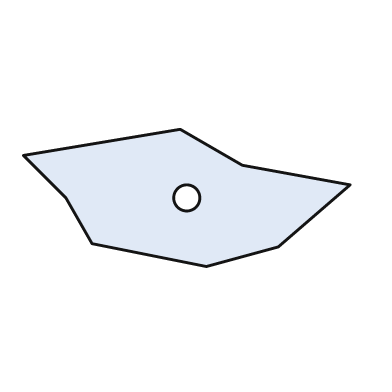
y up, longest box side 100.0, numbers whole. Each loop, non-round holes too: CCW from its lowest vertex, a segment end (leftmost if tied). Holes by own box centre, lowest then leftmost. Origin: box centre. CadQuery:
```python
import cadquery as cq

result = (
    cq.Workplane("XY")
    .moveTo(6.0, -21.0)
    .lineTo(28.0, -15.0)
    .lineTo(50.0, 4.0)
    .lineTo(17.0, 10.0)
    .lineTo(-2.0, 21.0)
    .lineTo(-50.0, 13.0)
    .lineTo(-37.0, 0.0)
    .lineTo(-29.0, -14.0)
    .close()
    .moveTo(0.0, 0.0)
    .circle(4.0)
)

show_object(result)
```